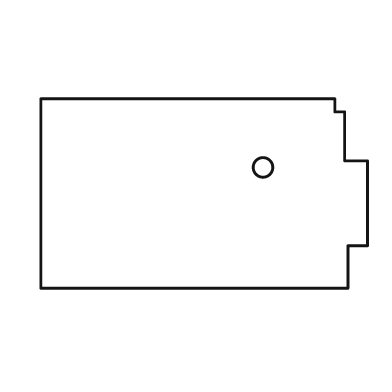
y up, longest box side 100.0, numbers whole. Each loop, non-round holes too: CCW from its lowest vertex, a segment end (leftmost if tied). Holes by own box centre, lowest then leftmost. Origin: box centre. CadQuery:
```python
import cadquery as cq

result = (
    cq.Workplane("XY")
    .moveTo(-50.0, -29.0)
    .lineTo(44.0, -29.0)
    .lineTo(44.0, -16.0)
    .lineTo(50.0, -16.0)
    .lineTo(50.0, 10.0)
    .lineTo(43.0, 10.0)
    .lineTo(43.0, 25.0)
    .lineTo(40.0, 25.0)
    .lineTo(40.0, 29.0)
    .lineTo(-50.0, 29.0)
    .close()
    .moveTo(18.0, 8.0)
    .circle(3.0)
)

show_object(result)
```